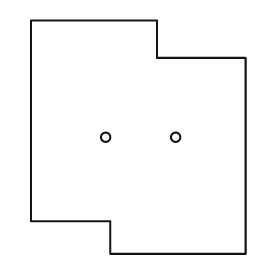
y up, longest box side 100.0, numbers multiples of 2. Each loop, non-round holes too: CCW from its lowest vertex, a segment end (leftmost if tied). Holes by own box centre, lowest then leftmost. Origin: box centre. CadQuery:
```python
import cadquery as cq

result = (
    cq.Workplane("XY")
    .moveTo(-12.0, -50.0)
    .lineTo(46.0, -50.0)
    .lineTo(46.0, 34.0)
    .lineTo(8.0, 34.0)
    .lineTo(8.0, 50.0)
    .lineTo(-46.0, 50.0)
    .lineTo(-46.0, -36.0)
    .lineTo(-12.0, -36.0)
    .close()
    .moveTo(-14.0, 0.0)
    .circle(2.0)
    .moveTo(16.0, 0.0)
    .circle(2.0)
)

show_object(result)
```